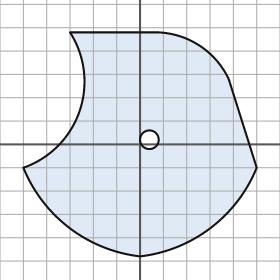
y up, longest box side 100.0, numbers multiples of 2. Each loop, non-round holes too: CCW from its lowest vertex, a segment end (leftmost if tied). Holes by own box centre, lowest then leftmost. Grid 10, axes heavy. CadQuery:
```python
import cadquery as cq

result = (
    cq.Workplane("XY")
    .moveTo(0.0, -48.0)
    .threePointArc((30.0, -36.0), (50.0, -10.0))
    .lineTo(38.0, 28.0)
    .threePointArc((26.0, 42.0), (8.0, 48.0))
    .lineTo(-30.0, 48.0)
    .threePointArc((-26.0, 14.0), (-50.0, -10.0))
    .threePointArc((-30.0, -36.0), (0.0, -48.0))
    .close()
    .moveTo(4.0, 2.0)
    .circle(4.0)
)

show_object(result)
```